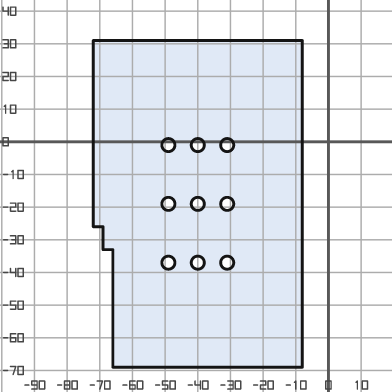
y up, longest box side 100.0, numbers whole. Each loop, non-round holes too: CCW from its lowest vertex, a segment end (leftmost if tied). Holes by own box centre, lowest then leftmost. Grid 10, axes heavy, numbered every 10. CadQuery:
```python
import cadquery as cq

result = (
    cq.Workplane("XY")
    .moveTo(-66.0, -69.0)
    .lineTo(-8.0, -69.0)
    .lineTo(-8.0, 31.0)
    .lineTo(-72.0, 31.0)
    .lineTo(-72.0, -26.0)
    .lineTo(-69.0, -26.0)
    .lineTo(-69.0, -33.0)
    .lineTo(-66.0, -33.0)
    .close()
    .moveTo(-49.0, -37.0)
    .circle(2.0)
    .moveTo(-40.0, -37.0)
    .circle(2.0)
    .moveTo(-31.0, -37.0)
    .circle(2.0)
    .moveTo(-49.0, -19.0)
    .circle(2.0)
    .moveTo(-40.0, -19.0)
    .circle(2.0)
    .moveTo(-31.0, -19.0)
    .circle(2.0)
    .moveTo(-49.0, -1.0)
    .circle(2.0)
    .moveTo(-40.0, -1.0)
    .circle(2.0)
    .moveTo(-31.0, -1.0)
    .circle(2.0)
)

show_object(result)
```